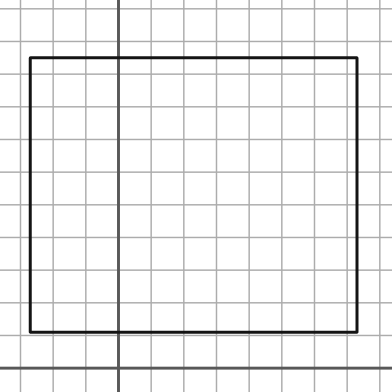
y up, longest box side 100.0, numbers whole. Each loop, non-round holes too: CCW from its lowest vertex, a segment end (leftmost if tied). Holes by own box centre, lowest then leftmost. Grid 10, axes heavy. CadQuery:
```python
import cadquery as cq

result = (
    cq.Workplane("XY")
    .moveTo(-27.0, 11.0)
    .lineTo(73.0, 11.0)
    .lineTo(73.0, 95.0)
    .lineTo(-27.0, 95.0)
    .close()
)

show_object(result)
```